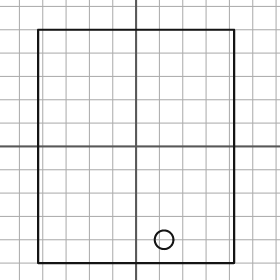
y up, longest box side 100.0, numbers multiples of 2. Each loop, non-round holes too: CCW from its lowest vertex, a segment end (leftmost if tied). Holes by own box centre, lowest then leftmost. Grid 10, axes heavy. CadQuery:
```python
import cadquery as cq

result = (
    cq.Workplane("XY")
    .moveTo(-42.0, -50.0)
    .lineTo(42.0, -50.0)
    .lineTo(42.0, 50.0)
    .lineTo(-42.0, 50.0)
    .close()
    .moveTo(12.0, -40.0)
    .circle(4.0)
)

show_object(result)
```